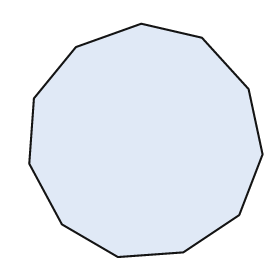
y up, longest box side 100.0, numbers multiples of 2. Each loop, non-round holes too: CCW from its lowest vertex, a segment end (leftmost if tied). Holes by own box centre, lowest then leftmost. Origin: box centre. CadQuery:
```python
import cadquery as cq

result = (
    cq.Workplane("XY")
    .moveTo(-12.0, -50.0)
    .lineTo(16.0, -48.0)
    .lineTo(40.0, -32.0)
    .lineTo(50.0, -6.0)
    .lineTo(44.0, 22.0)
    .lineTo(24.0, 44.0)
    .lineTo(-2.0, 50.0)
    .lineTo(-30.0, 40.0)
    .lineTo(-48.0, 18.0)
    .lineTo(-50.0, -10.0)
    .lineTo(-36.0, -36.0)
    .close()
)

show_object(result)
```